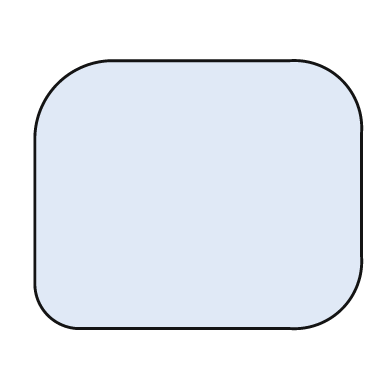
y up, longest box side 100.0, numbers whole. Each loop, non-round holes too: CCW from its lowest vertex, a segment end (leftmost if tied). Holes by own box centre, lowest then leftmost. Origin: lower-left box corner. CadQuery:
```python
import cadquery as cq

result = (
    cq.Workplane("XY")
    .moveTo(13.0, 0.0)
    .lineTo(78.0, 0.0)
    .threePointArc((94.0, 6.0), (100.0, 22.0))
    .lineTo(100.0, 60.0)
    .threePointArc((94.0, 76.0), (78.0, 82.0))
    .lineTo(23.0, 82.0)
    .threePointArc((7.0, 75.0), (0.0, 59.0))
    .lineTo(0.0, 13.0)
    .threePointArc((4.0, 4.0), (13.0, 0.0))
    .close()
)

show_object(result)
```